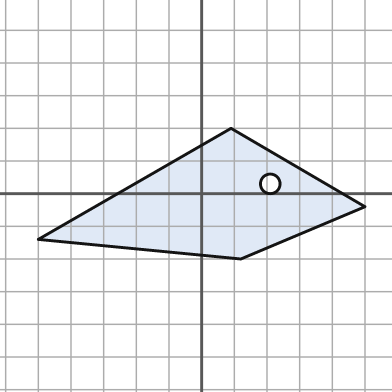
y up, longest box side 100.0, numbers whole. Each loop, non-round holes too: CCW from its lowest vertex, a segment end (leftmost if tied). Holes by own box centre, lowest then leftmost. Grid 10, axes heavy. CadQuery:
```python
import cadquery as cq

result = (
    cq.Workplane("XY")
    .moveTo(12.0, -20.0)
    .lineTo(50.0, -4.0)
    .lineTo(9.0, 20.0)
    .lineTo(-50.0, -14.0)
    .close()
    .moveTo(21.0, 3.0)
    .circle(3.0)
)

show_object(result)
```